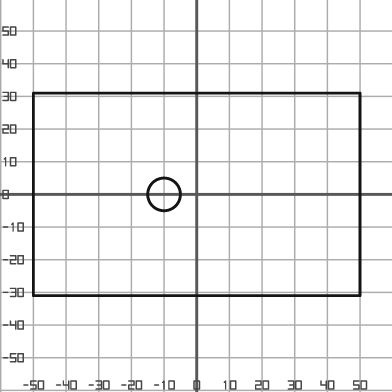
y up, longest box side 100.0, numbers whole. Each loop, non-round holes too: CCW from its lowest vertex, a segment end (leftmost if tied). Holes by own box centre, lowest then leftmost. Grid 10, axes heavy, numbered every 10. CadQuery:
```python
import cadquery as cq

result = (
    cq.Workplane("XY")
    .moveTo(-50.0, -31.0)
    .lineTo(50.0, -31.0)
    .lineTo(50.0, 31.0)
    .lineTo(-50.0, 31.0)
    .close()
    .moveTo(-10.0, 0.0)
    .circle(5.0)
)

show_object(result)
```